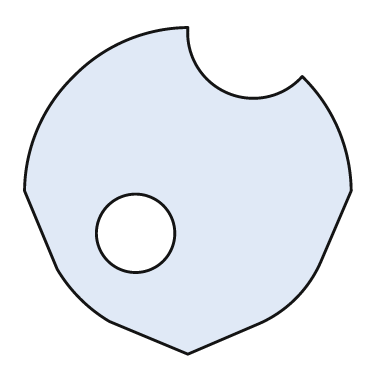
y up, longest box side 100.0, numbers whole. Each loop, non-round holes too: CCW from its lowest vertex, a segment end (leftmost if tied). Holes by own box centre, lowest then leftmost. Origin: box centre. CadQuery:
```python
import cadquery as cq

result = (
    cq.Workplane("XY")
    .moveTo(0.0, -50.0)
    .lineTo(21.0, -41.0)
    .threePointArc((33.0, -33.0), (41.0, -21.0))
    .lineTo(50.0, 0.0)
    .threePointArc((46.0, 19.0), (35.0, 35.0))
    .threePointArc((12.0, 30.0), (0.0, 50.0))
    .threePointArc((-19.0, 46.0), (-35.0, 35.0))
    .threePointArc((-46.0, 19.0), (-50.0, 0.0))
    .lineTo(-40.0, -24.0)
    .threePointArc((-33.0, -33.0), (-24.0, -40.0))
    .close()
    .moveTo(-16.0, -13.0)
    .circle(12.0)
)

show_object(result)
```